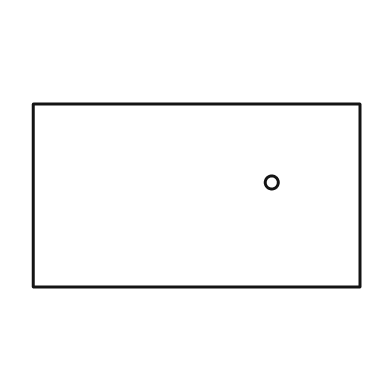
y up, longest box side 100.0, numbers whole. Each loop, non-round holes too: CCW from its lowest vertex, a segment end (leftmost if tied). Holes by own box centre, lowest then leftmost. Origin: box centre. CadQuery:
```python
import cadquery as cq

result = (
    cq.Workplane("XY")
    .moveTo(-50.0, -28.0)
    .lineTo(50.0, -28.0)
    .lineTo(50.0, 28.0)
    .lineTo(-50.0, 28.0)
    .close()
    .moveTo(23.0, 4.0)
    .circle(2.0)
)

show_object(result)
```